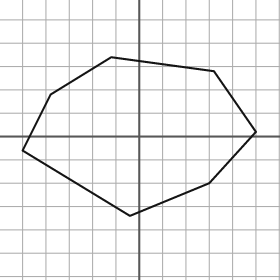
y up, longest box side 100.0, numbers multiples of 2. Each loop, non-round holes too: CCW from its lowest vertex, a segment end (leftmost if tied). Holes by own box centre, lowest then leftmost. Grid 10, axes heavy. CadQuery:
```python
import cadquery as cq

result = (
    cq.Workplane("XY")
    .moveTo(-4.0, -34.0)
    .lineTo(30.0, -20.0)
    .lineTo(50.0, 2.0)
    .lineTo(32.0, 28.0)
    .lineTo(-12.0, 34.0)
    .lineTo(-38.0, 18.0)
    .lineTo(-50.0, -6.0)
    .close()
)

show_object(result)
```